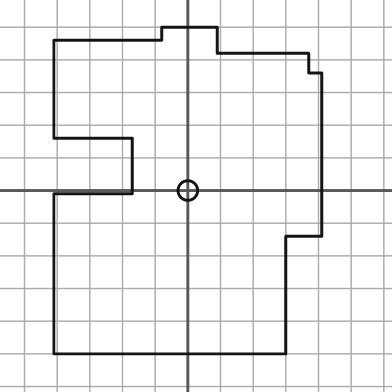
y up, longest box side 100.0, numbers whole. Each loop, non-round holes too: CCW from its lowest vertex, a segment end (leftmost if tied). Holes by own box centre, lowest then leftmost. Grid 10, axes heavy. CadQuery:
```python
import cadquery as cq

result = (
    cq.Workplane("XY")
    .moveTo(-41.0, -50.0)
    .lineTo(30.0, -50.0)
    .lineTo(30.0, -14.0)
    .lineTo(41.0, -14.0)
    .lineTo(41.0, 36.0)
    .lineTo(37.0, 36.0)
    .lineTo(37.0, 42.0)
    .lineTo(9.0, 42.0)
    .lineTo(9.0, 50.0)
    .lineTo(-8.0, 50.0)
    .lineTo(-8.0, 46.0)
    .lineTo(-41.0, 46.0)
    .lineTo(-41.0, 16.0)
    .lineTo(-17.0, 16.0)
    .lineTo(-17.0, -1.0)
    .lineTo(-41.0, -1.0)
    .close()
    .moveTo(0.0, 0.0)
    .circle(3.0)
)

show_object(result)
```